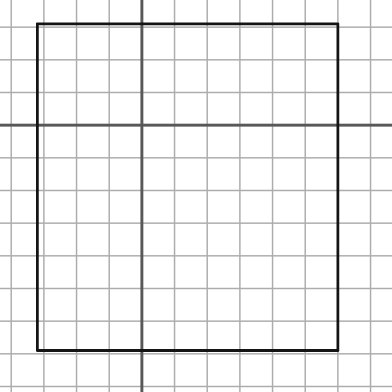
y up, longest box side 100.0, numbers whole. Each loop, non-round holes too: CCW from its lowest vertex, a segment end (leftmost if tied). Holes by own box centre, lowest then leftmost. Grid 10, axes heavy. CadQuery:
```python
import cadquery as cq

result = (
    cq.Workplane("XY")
    .moveTo(-32.0, -69.0)
    .lineTo(60.0, -69.0)
    .lineTo(60.0, 31.0)
    .lineTo(-32.0, 31.0)
    .close()
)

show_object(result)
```